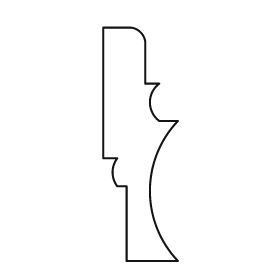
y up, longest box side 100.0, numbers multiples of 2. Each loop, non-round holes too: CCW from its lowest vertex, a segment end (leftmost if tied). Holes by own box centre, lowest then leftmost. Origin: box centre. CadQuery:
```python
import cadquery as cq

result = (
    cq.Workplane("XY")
    .moveTo(-6.0, -50.0)
    .lineTo(16.0, -50.0)
    .threePointArc((4.0, -20.0), (16.0, 10.0))
    .lineTo(8.0, 10.0)
    .threePointArc((4.0, 18.0), (8.0, 26.0))
    .lineTo(2.0, 26.0)
    .lineTo(2.0, 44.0)
    .threePointArc((0.0, 48.0), (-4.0, 50.0))
    .lineTo(-16.0, 50.0)
    .lineTo(-16.0, -6.0)
    .lineTo(-10.0, -6.0)
    .threePointArc((-12.0, -12.0), (-10.0, -18.0))
    .lineTo(-6.0, -18.0)
    .close()
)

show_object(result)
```